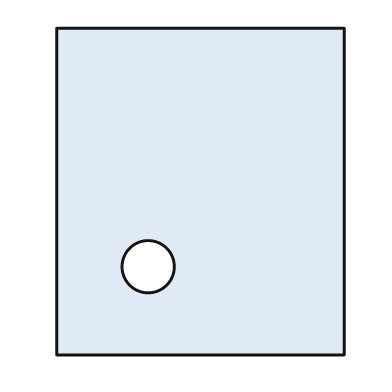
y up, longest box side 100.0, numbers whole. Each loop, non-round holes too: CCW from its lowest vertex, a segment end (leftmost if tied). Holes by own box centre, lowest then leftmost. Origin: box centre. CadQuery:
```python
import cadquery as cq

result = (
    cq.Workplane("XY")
    .moveTo(-44.0, -50.0)
    .lineTo(44.0, -50.0)
    .lineTo(44.0, 50.0)
    .lineTo(-44.0, 50.0)
    .close()
    .moveTo(-16.0, -23.0)
    .circle(8.0)
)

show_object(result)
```